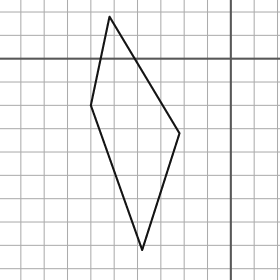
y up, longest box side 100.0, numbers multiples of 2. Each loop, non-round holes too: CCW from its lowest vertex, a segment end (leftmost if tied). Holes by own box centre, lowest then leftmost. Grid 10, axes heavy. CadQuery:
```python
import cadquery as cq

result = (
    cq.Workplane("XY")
    .moveTo(-38.0, -82.0)
    .lineTo(-22.0, -32.0)
    .lineTo(-52.0, 18.0)
    .lineTo(-60.0, -20.0)
    .close()
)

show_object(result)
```